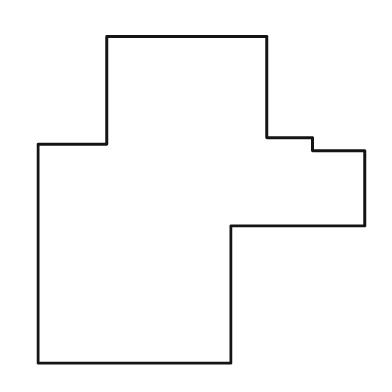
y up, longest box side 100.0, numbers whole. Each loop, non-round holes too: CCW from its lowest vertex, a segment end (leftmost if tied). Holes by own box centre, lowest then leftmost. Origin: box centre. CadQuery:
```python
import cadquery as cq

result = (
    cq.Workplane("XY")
    .moveTo(-50.0, -50.0)
    .lineTo(9.0, -50.0)
    .lineTo(9.0, -8.0)
    .lineTo(50.0, -8.0)
    .lineTo(50.0, 15.0)
    .lineTo(34.0, 15.0)
    .lineTo(34.0, 19.0)
    .lineTo(20.0, 19.0)
    .lineTo(20.0, 50.0)
    .lineTo(-29.0, 50.0)
    .lineTo(-29.0, 17.0)
    .lineTo(-50.0, 17.0)
    .close()
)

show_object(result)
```